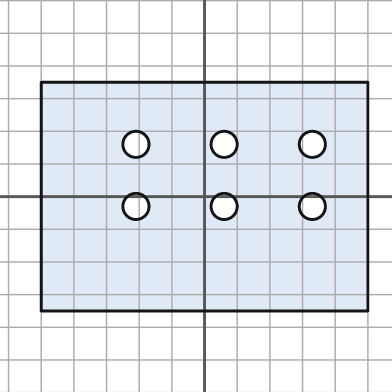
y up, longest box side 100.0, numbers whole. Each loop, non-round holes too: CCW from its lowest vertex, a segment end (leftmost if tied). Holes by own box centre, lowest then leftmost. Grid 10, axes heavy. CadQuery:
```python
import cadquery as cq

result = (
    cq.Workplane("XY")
    .moveTo(-50.0, -35.0)
    .lineTo(50.0, -35.0)
    .lineTo(50.0, 35.0)
    .lineTo(-50.0, 35.0)
    .close()
    .moveTo(-21.0, -3.0)
    .circle(4.0)
    .moveTo(6.0, -3.0)
    .circle(4.0)
    .moveTo(33.0, -3.0)
    .circle(4.0)
    .moveTo(-21.0, 16.0)
    .circle(4.0)
    .moveTo(6.0, 16.0)
    .circle(4.0)
    .moveTo(33.0, 16.0)
    .circle(4.0)
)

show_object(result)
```